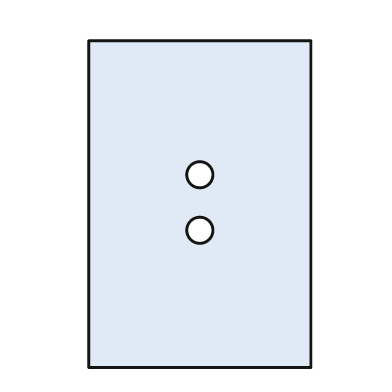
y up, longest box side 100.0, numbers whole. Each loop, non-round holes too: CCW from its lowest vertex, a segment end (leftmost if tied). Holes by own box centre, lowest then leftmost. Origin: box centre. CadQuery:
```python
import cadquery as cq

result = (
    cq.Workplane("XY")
    .moveTo(-34.0, -50.0)
    .lineTo(34.0, -50.0)
    .lineTo(34.0, 50.0)
    .lineTo(-34.0, 50.0)
    .close()
    .moveTo(0.0, -8.0)
    .circle(4.0)
    .moveTo(0.0, 9.0)
    .circle(4.0)
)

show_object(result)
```